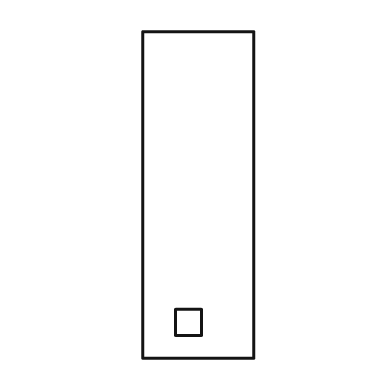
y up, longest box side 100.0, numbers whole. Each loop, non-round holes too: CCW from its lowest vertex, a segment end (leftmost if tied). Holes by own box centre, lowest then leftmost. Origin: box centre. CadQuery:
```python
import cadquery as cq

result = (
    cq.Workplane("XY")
    .moveTo(-17.0, -50.0)
    .lineTo(17.0, -50.0)
    .lineTo(17.0, 50.0)
    .lineTo(-17.0, 50.0)
    .close()
    .moveTo(-7.0, -43.0)
    .lineTo(1.0, -43.0)
    .lineTo(1.0, -35.0)
    .lineTo(-7.0, -35.0)
    .close()
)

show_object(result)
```